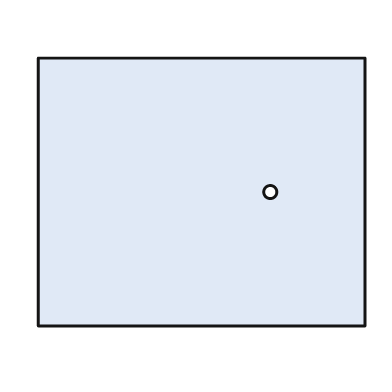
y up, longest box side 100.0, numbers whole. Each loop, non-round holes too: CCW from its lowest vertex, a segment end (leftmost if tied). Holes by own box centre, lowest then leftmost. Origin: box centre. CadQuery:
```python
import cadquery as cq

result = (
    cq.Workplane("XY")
    .moveTo(-50.0, -41.0)
    .lineTo(50.0, -41.0)
    .lineTo(50.0, 41.0)
    .lineTo(-50.0, 41.0)
    .close()
    .moveTo(21.0, 0.0)
    .circle(2.0)
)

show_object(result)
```